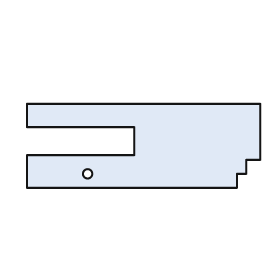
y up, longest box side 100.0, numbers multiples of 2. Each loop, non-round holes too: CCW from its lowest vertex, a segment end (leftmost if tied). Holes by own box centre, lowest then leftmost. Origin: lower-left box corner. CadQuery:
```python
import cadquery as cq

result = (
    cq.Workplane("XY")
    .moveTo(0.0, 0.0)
    .lineTo(90.0, 0.0)
    .lineTo(90.0, 6.0)
    .lineTo(94.0, 6.0)
    .lineTo(94.0, 12.0)
    .lineTo(100.0, 12.0)
    .lineTo(100.0, 36.0)
    .lineTo(0.0, 36.0)
    .lineTo(0.0, 26.0)
    .lineTo(46.0, 26.0)
    .lineTo(46.0, 14.0)
    .lineTo(0.0, 14.0)
    .close()
    .moveTo(26.0, 6.0)
    .circle(2.0)
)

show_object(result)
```